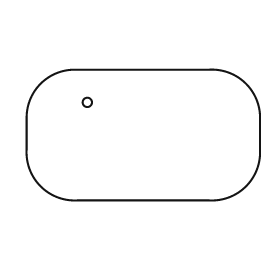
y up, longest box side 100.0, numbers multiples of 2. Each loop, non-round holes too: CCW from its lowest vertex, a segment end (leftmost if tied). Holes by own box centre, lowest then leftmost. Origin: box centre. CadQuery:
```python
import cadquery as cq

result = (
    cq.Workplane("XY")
    .moveTo(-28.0, -28.0)
    .lineTo(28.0, -28.0)
    .threePointArc((44.0, -22.0), (50.0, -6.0))
    .lineTo(50.0, 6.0)
    .threePointArc((44.0, 22.0), (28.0, 28.0))
    .lineTo(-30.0, 28.0)
    .threePointArc((-44.0, 22.0), (-50.0, 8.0))
    .lineTo(-50.0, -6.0)
    .threePointArc((-44.0, -22.0), (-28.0, -28.0))
    .close()
    .moveTo(-24.0, 14.0)
    .circle(2.0)
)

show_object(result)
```